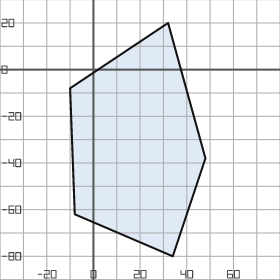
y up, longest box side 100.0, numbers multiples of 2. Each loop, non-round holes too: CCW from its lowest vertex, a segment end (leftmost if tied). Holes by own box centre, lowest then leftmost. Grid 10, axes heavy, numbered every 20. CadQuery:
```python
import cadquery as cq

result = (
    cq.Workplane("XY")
    .moveTo(34.0, -80.0)
    .lineTo(48.0, -38.0)
    .lineTo(32.0, 20.0)
    .lineTo(-10.0, -8.0)
    .lineTo(-8.0, -62.0)
    .close()
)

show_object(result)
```